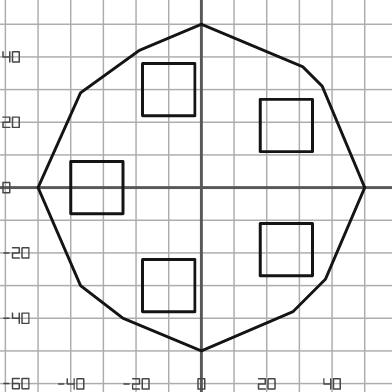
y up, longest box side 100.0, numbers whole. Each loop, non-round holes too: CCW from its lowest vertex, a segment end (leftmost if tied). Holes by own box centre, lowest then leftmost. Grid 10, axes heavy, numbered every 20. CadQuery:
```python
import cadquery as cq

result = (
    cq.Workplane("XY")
    .moveTo(0.0, -50.0)
    .lineTo(28.0, -38.0)
    .lineTo(38.0, -28.0)
    .lineTo(50.0, 0.0)
    .lineTo(37.0, 31.0)
    .lineTo(31.0, 37.0)
    .lineTo(0.0, 50.0)
    .lineTo(-19.0, 42.0)
    .lineTo(-37.0, 29.0)
    .lineTo(-50.0, 0.0)
    .lineTo(-37.0, -30.0)
    .lineTo(-24.0, -40.0)
    .close()
    .moveTo(-18.0, -38.0)
    .lineTo(-2.0, -38.0)
    .lineTo(-2.0, -22.0)
    .lineTo(-18.0, -22.0)
    .close()
    .moveTo(18.0, -27.0)
    .lineTo(34.0, -27.0)
    .lineTo(34.0, -11.0)
    .lineTo(18.0, -11.0)
    .close()
    .moveTo(-40.0, -8.0)
    .lineTo(-24.0, -8.0)
    .lineTo(-24.0, 8.0)
    .lineTo(-40.0, 8.0)
    .close()
    .moveTo(18.0, 11.0)
    .lineTo(34.0, 11.0)
    .lineTo(34.0, 27.0)
    .lineTo(18.0, 27.0)
    .close()
    .moveTo(-18.0, 22.0)
    .lineTo(-2.0, 22.0)
    .lineTo(-2.0, 38.0)
    .lineTo(-18.0, 38.0)
    .close()
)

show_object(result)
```